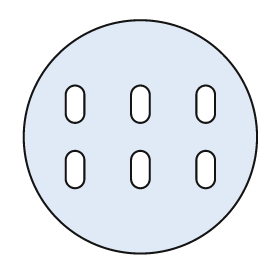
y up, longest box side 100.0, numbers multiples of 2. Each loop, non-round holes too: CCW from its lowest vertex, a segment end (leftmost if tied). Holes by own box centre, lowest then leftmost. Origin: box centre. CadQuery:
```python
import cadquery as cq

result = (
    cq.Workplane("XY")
    .moveTo(0.0, 0.0)
    .circle(50.0)
    .moveTo(-32.0, -18.0)
    .threePointArc((-28.0, -22.0), (-24.0, -18.0))
    .lineTo(-24.0, -10.0)
    .threePointArc((-28.0, -6.0), (-32.0, -10.0))
    .close()
    .moveTo(-4.0, -18.0)
    .threePointArc((0.0, -22.0), (4.0, -18.0))
    .lineTo(4.0, -10.0)
    .threePointArc((0.0, -6.0), (-4.0, -10.0))
    .close()
    .moveTo(24.0, -18.0)
    .threePointArc((28.0, -22.0), (32.0, -18.0))
    .lineTo(32.0, -10.0)
    .threePointArc((28.0, -6.0), (24.0, -10.0))
    .close()
    .moveTo(-32.0, 10.0)
    .threePointArc((-28.0, 6.0), (-24.0, 10.0))
    .lineTo(-24.0, 18.0)
    .threePointArc((-28.0, 22.0), (-32.0, 18.0))
    .close()
    .moveTo(-4.0, 10.0)
    .threePointArc((0.0, 6.0), (4.0, 10.0))
    .lineTo(4.0, 18.0)
    .threePointArc((0.0, 22.0), (-4.0, 18.0))
    .close()
    .moveTo(24.0, 10.0)
    .threePointArc((28.0, 6.0), (32.0, 10.0))
    .lineTo(32.0, 18.0)
    .threePointArc((28.0, 22.0), (24.0, 18.0))
    .close()
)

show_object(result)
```